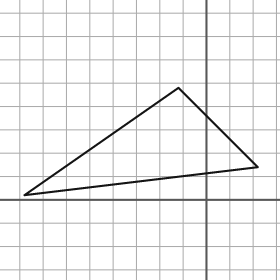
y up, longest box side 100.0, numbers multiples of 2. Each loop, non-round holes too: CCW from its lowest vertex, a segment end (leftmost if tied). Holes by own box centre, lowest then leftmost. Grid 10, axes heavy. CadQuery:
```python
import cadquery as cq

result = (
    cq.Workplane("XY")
    .moveTo(-78.0, 2.0)
    .lineTo(22.0, 14.0)
    .lineTo(-12.0, 48.0)
    .close()
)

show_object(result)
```